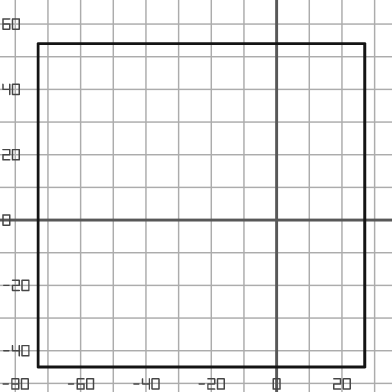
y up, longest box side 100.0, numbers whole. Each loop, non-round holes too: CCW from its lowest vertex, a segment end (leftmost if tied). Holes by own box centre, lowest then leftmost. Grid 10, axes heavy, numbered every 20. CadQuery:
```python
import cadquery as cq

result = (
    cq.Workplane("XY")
    .moveTo(-73.0, -45.0)
    .lineTo(27.0, -45.0)
    .lineTo(27.0, 54.0)
    .lineTo(-73.0, 54.0)
    .close()
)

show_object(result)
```